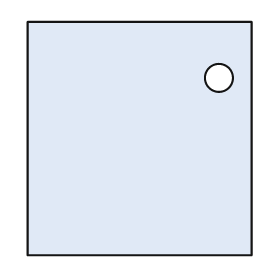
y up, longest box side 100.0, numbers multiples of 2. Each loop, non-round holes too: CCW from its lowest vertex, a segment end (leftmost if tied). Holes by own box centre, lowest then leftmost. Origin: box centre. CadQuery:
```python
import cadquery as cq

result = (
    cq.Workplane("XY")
    .moveTo(-48.0, -50.0)
    .lineTo(48.0, -50.0)
    .lineTo(48.0, 50.0)
    .lineTo(-48.0, 50.0)
    .close()
    .moveTo(34.0, 26.0)
    .circle(6.0)
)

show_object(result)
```